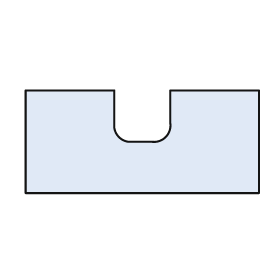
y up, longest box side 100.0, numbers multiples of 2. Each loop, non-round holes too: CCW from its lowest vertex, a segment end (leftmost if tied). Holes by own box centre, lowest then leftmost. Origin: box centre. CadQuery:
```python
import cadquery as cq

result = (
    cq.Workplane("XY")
    .moveTo(-50.0, -22.0)
    .lineTo(50.0, -22.0)
    .lineTo(50.0, 22.0)
    .lineTo(12.0, 22.0)
    .lineTo(12.0, 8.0)
    .threePointArc((10.0, 2.0), (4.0, 0.0))
    .lineTo(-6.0, 0.0)
    .threePointArc((-10.0, 2.0), (-12.0, 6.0))
    .lineTo(-12.0, 22.0)
    .lineTo(-50.0, 22.0)
    .close()
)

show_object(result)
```